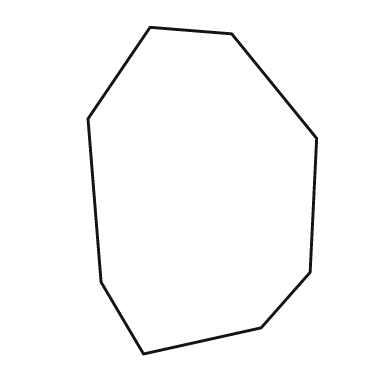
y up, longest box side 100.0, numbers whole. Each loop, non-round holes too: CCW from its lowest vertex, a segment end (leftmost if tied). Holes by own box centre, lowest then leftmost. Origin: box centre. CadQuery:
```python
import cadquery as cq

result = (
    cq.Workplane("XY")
    .moveTo(-18.0, -50.0)
    .lineTo(18.0, -42.0)
    .lineTo(33.0, -25.0)
    .lineTo(35.0, 16.0)
    .lineTo(9.0, 48.0)
    .lineTo(-16.0, 50.0)
    .lineTo(-35.0, 22.0)
    .lineTo(-31.0, -28.0)
    .close()
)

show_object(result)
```